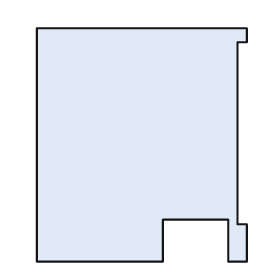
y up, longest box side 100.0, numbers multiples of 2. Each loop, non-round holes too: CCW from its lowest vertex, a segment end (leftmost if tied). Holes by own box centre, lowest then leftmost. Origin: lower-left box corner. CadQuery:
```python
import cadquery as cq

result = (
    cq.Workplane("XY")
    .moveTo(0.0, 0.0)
    .lineTo(54.0, 0.0)
    .lineTo(54.0, 18.0)
    .lineTo(82.0, 18.0)
    .lineTo(82.0, 0.0)
    .lineTo(90.0, 0.0)
    .lineTo(90.0, 16.0)
    .lineTo(86.0, 16.0)
    .lineTo(86.0, 94.0)
    .lineTo(90.0, 94.0)
    .lineTo(90.0, 100.0)
    .lineTo(0.0, 100.0)
    .close()
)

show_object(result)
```